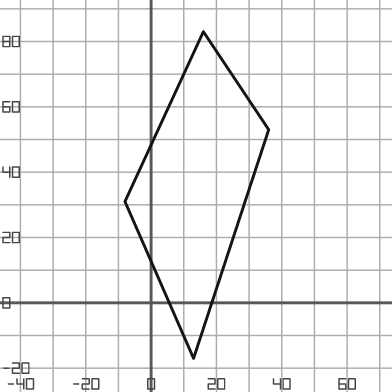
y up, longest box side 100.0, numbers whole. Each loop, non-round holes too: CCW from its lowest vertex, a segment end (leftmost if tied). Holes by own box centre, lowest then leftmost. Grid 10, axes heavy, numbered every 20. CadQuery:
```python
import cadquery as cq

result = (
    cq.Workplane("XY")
    .moveTo(13.0, -17.0)
    .lineTo(36.0, 53.0)
    .lineTo(16.0, 83.0)
    .lineTo(-8.0, 31.0)
    .close()
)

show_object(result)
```